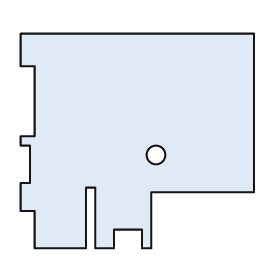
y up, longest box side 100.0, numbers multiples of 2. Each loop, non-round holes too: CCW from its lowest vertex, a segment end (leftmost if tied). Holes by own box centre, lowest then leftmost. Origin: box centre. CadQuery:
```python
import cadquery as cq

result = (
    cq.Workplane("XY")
    .moveTo(-44.0, -46.0)
    .lineTo(-22.0, -46.0)
    .lineTo(-22.0, -20.0)
    .lineTo(-18.0, -20.0)
    .lineTo(-18.0, -46.0)
    .lineTo(-10.0, -46.0)
    .lineTo(-10.0, -38.0)
    .lineTo(2.0, -38.0)
    .lineTo(2.0, -46.0)
    .lineTo(6.0, -46.0)
    .lineTo(6.0, -22.0)
    .lineTo(50.0, -22.0)
    .lineTo(50.0, 46.0)
    .lineTo(-50.0, 46.0)
    .lineTo(-50.0, 32.0)
    .lineTo(-44.0, 32.0)
    .lineTo(-44.0, 2.0)
    .lineTo(-50.0, 2.0)
    .lineTo(-50.0, -2.0)
    .lineTo(-46.0, -2.0)
    .lineTo(-46.0, -18.0)
    .lineTo(-50.0, -18.0)
    .lineTo(-50.0, -30.0)
    .lineTo(-44.0, -30.0)
    .close()
    .moveTo(8.0, -6.0)
    .circle(4.0)
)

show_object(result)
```